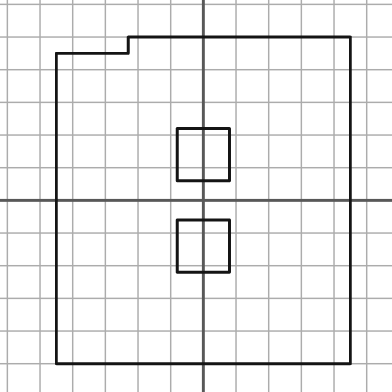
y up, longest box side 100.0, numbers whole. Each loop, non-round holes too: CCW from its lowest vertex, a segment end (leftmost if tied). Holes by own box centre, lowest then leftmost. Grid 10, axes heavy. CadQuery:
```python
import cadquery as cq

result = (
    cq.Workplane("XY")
    .moveTo(-45.0, -50.0)
    .lineTo(45.0, -50.0)
    .lineTo(45.0, 50.0)
    .lineTo(-23.0, 50.0)
    .lineTo(-23.0, 45.0)
    .lineTo(-45.0, 45.0)
    .close()
    .moveTo(-8.0, -22.0)
    .lineTo(8.0, -22.0)
    .lineTo(8.0, -6.0)
    .lineTo(-8.0, -6.0)
    .close()
    .moveTo(-8.0, 6.0)
    .lineTo(8.0, 6.0)
    .lineTo(8.0, 22.0)
    .lineTo(-8.0, 22.0)
    .close()
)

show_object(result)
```